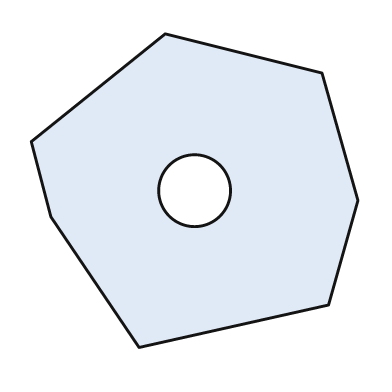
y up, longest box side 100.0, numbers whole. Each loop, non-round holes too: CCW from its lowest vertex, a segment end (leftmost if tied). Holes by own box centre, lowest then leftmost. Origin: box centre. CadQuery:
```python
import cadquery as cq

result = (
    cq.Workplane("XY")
    .moveTo(-17.0, -48.0)
    .lineTo(41.0, -35.0)
    .lineTo(50.0, -3.0)
    .lineTo(39.0, 36.0)
    .lineTo(-9.0, 48.0)
    .lineTo(-50.0, 15.0)
    .lineTo(-44.0, -8.0)
    .close()
    .moveTo(0.0, 0.0)
    .circle(11.0)
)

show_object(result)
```